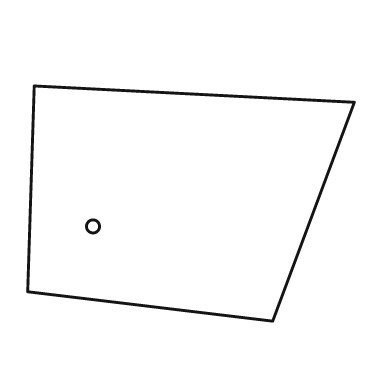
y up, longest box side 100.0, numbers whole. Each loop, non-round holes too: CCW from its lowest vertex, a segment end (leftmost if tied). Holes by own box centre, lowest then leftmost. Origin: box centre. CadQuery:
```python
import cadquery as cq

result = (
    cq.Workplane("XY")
    .moveTo(25.0, -36.0)
    .lineTo(50.0, 31.0)
    .lineTo(-48.0, 36.0)
    .lineTo(-50.0, -27.0)
    .close()
    .moveTo(-30.0, -7.0)
    .circle(2.0)
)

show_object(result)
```